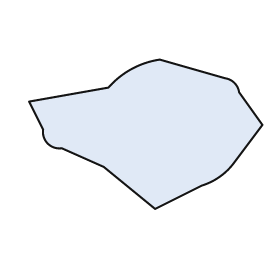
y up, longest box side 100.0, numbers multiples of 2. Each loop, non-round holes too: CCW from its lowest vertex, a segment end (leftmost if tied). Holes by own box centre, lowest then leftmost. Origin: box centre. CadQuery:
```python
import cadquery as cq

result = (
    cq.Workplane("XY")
    .moveTo(4.0, -32.0)
    .lineTo(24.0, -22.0)
    .threePointArc((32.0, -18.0), (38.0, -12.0))
    .lineTo(50.0, 4.0)
    .lineTo(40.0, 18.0)
    .threePointArc((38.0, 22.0), (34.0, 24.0))
    .lineTo(6.0, 32.0)
    .threePointArc((-6.0, 28.0), (-16.0, 20.0))
    .lineTo(-50.0, 14.0)
    .lineTo(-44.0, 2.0)
    .threePointArc((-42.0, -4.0), (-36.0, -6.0))
    .lineTo(-18.0, -14.0)
    .close()
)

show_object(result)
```